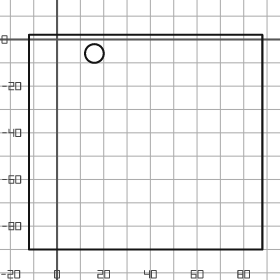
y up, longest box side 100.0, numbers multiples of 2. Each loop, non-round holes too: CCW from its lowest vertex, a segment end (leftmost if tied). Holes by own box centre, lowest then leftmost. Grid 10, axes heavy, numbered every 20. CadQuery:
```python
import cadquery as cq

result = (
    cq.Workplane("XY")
    .moveTo(-12.0, -90.0)
    .lineTo(88.0, -90.0)
    .lineTo(88.0, 2.0)
    .lineTo(-12.0, 2.0)
    .close()
    .moveTo(16.0, -6.0)
    .circle(4.0)
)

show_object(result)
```